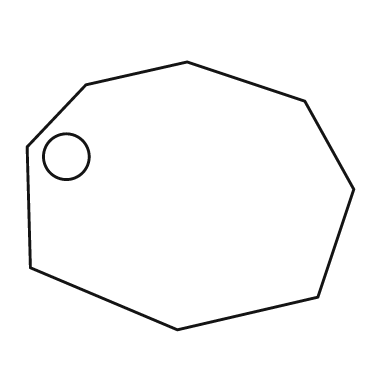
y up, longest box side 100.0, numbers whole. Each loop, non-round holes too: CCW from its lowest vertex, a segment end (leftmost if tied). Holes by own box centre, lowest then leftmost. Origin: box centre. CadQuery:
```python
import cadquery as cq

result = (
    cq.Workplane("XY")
    .moveTo(-4.0, -41.0)
    .lineTo(39.0, -31.0)
    .lineTo(50.0, 2.0)
    .lineTo(35.0, 29.0)
    .lineTo(-1.0, 41.0)
    .lineTo(-32.0, 34.0)
    .lineTo(-50.0, 15.0)
    .lineTo(-49.0, -22.0)
    .close()
    .moveTo(-38.0, 12.0)
    .circle(7.0)
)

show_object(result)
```